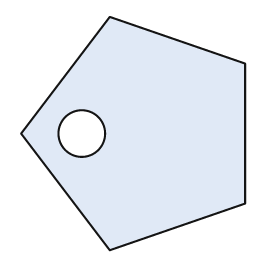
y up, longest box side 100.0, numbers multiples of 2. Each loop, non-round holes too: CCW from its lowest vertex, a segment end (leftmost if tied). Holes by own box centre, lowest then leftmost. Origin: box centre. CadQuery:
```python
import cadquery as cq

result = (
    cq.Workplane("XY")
    .moveTo(-10.0, -50.0)
    .lineTo(48.0, -30.0)
    .lineTo(48.0, 30.0)
    .lineTo(-10.0, 50.0)
    .lineTo(-48.0, 0.0)
    .close()
    .moveTo(-22.0, 0.0)
    .circle(10.0)
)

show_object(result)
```